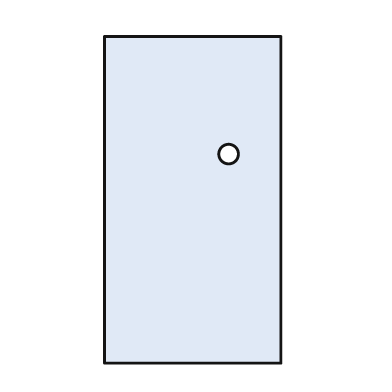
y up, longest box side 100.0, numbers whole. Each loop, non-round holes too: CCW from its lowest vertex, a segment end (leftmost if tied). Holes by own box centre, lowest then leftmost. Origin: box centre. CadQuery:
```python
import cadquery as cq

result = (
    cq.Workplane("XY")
    .moveTo(-27.0, -50.0)
    .lineTo(27.0, -50.0)
    .lineTo(27.0, 50.0)
    .lineTo(-27.0, 50.0)
    .close()
    .moveTo(11.0, 14.0)
    .circle(3.0)
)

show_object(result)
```